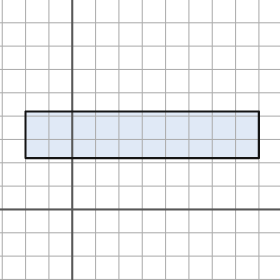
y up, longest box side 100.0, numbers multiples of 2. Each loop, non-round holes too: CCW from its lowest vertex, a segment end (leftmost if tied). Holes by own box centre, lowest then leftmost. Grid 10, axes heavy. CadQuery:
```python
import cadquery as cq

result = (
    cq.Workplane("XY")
    .moveTo(-20.0, 22.0)
    .lineTo(80.0, 22.0)
    .lineTo(80.0, 42.0)
    .lineTo(-20.0, 42.0)
    .close()
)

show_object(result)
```